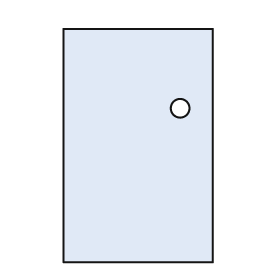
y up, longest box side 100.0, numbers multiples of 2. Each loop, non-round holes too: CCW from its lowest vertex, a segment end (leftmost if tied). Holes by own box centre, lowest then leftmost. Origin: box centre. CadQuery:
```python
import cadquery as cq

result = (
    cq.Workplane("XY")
    .moveTo(-32.0, -50.0)
    .lineTo(32.0, -50.0)
    .lineTo(32.0, 50.0)
    .lineTo(-32.0, 50.0)
    .close()
    .moveTo(18.0, 16.0)
    .circle(4.0)
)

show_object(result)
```